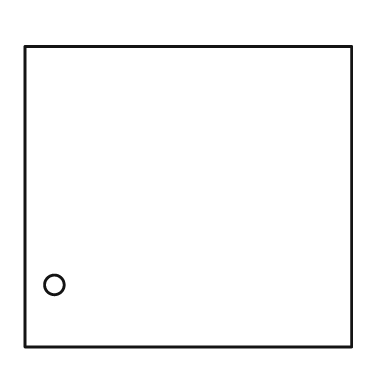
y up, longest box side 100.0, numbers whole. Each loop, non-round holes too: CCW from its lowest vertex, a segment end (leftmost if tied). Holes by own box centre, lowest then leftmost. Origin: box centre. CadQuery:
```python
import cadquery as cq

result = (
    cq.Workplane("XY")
    .moveTo(-50.0, -46.0)
    .lineTo(50.0, -46.0)
    .lineTo(50.0, 46.0)
    .lineTo(-50.0, 46.0)
    .close()
    .moveTo(-41.0, -27.0)
    .circle(3.0)
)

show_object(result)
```